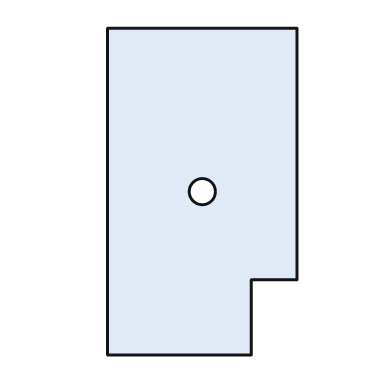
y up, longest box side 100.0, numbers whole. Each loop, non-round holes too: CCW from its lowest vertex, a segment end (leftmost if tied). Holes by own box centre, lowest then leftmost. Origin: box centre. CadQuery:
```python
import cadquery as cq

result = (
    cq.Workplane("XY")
    .moveTo(-29.0, -50.0)
    .lineTo(15.0, -50.0)
    .lineTo(15.0, -27.0)
    .lineTo(29.0, -27.0)
    .lineTo(29.0, 50.0)
    .lineTo(-29.0, 50.0)
    .close()
    .moveTo(0.0, 0.0)
    .circle(4.0)
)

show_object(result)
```